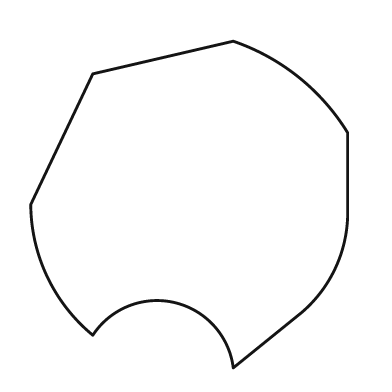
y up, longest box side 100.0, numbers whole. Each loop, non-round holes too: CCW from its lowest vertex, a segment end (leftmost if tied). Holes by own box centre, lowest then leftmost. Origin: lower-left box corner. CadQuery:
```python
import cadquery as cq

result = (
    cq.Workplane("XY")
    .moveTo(62.0, 0.0)
    .lineTo(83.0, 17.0)
    .threePointArc((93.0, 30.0), (97.0, 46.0))
    .lineTo(97.0, 72.0)
    .threePointArc((82.0, 89.0), (62.0, 100.0))
    .lineTo(19.0, 90.0)
    .lineTo(0.0, 50.0)
    .threePointArc((5.0, 28.0), (19.0, 10.0))
    .threePointArc((44.0, 20.0), (62.0, 0.0))
    .close()
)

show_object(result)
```